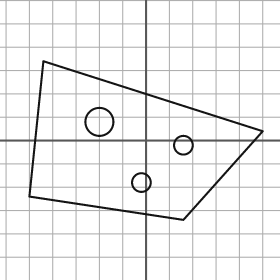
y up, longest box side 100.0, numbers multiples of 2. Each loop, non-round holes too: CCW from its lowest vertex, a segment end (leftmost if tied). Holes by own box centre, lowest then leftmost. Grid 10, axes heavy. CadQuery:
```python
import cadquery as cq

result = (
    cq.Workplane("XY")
    .moveTo(16.0, -34.0)
    .lineTo(50.0, 4.0)
    .lineTo(-44.0, 34.0)
    .lineTo(-50.0, -24.0)
    .close()
    .moveTo(-2.0, -18.0)
    .circle(4.0)
    .moveTo(16.0, -2.0)
    .circle(4.0)
    .moveTo(-20.0, 8.0)
    .circle(6.0)
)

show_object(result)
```